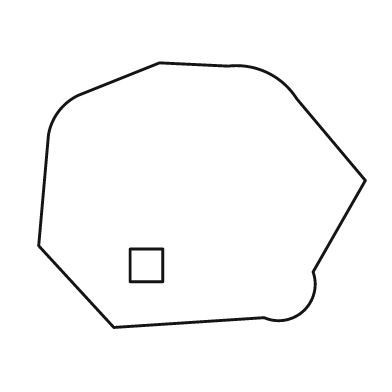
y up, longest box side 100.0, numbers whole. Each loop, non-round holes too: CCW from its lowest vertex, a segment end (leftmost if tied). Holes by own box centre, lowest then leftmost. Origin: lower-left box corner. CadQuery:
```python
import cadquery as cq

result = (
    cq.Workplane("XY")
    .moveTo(23.0, 0.0)
    .lineTo(69.0, 3.0)
    .threePointArc((81.0, 5.0), (84.0, 17.0))
    .lineTo(100.0, 45.0)
    .lineTo(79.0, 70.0)
    .threePointArc((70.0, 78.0), (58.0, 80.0))
    .lineTo(37.0, 81.0)
    .lineTo(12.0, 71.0)
    .threePointArc((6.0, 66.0), (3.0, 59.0))
    .lineTo(0.0, 25.0)
    .close()
    .moveTo(28.0, 14.0)
    .lineTo(38.0, 14.0)
    .lineTo(38.0, 24.0)
    .lineTo(28.0, 24.0)
    .close()
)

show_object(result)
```